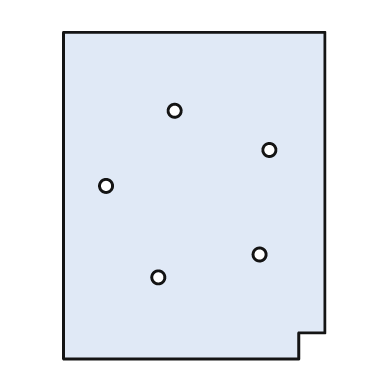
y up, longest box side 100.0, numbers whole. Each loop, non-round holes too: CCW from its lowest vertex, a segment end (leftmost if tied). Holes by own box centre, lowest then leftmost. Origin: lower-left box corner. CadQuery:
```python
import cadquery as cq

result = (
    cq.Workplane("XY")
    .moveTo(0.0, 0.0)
    .lineTo(72.0, 0.0)
    .lineTo(72.0, 8.0)
    .lineTo(80.0, 8.0)
    .lineTo(80.0, 100.0)
    .lineTo(0.0, 100.0)
    .close()
    .moveTo(29.0, 25.0)
    .circle(2.0)
    .moveTo(60.0, 32.0)
    .circle(2.0)
    .moveTo(13.0, 53.0)
    .circle(2.0)
    .moveTo(63.0, 64.0)
    .circle(2.0)
    .moveTo(34.0, 76.0)
    .circle(2.0)
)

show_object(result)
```